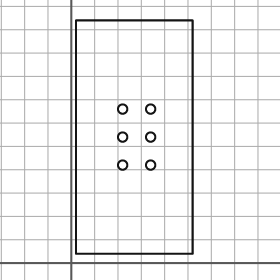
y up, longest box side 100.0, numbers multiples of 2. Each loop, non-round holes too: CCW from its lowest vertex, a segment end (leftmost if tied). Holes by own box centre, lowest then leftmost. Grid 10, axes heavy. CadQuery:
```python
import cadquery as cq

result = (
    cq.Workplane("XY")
    .moveTo(2.0, 4.0)
    .lineTo(52.0, 4.0)
    .lineTo(52.0, 104.0)
    .lineTo(2.0, 104.0)
    .close()
    .moveTo(22.0, 42.0)
    .circle(2.0)
    .moveTo(34.0, 42.0)
    .circle(2.0)
    .moveTo(22.0, 54.0)
    .circle(2.0)
    .moveTo(34.0, 54.0)
    .circle(2.0)
    .moveTo(22.0, 66.0)
    .circle(2.0)
    .moveTo(34.0, 66.0)
    .circle(2.0)
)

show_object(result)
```